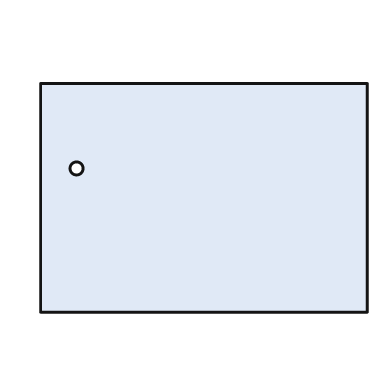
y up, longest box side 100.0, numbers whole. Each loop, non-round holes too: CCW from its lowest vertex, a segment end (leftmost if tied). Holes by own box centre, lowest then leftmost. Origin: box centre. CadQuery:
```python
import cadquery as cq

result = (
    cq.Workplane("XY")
    .moveTo(-50.0, -35.0)
    .lineTo(50.0, -35.0)
    .lineTo(50.0, 35.0)
    .lineTo(-50.0, 35.0)
    .close()
    .moveTo(-39.0, 9.0)
    .circle(2.0)
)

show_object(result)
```